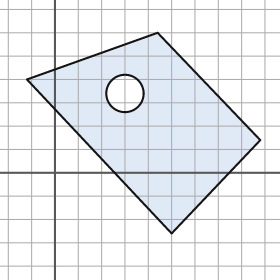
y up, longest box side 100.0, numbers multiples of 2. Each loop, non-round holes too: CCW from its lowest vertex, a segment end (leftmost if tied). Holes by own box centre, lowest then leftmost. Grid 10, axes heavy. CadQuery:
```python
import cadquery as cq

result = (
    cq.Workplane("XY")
    .moveTo(50.0, -26.0)
    .lineTo(88.0, 14.0)
    .lineTo(44.0, 60.0)
    .lineTo(-12.0, 40.0)
    .close()
    .moveTo(30.0, 34.0)
    .circle(8.0)
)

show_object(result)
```